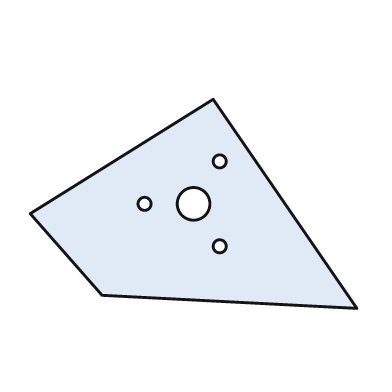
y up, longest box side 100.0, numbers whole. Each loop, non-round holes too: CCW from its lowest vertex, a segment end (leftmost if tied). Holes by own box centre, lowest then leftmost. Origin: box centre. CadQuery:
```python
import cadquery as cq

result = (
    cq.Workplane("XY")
    .moveTo(50.0, -32.0)
    .lineTo(6.0, 32.0)
    .lineTo(-50.0, -3.0)
    .lineTo(-28.0, -28.0)
    .close()
    .moveTo(8.0, -13.0)
    .circle(2.0)
    .moveTo(-15.0, 0.0)
    .circle(2.0)
    .moveTo(0.0, 0.0)
    .circle(5.0)
    .moveTo(8.0, 13.0)
    .circle(2.0)
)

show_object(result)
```